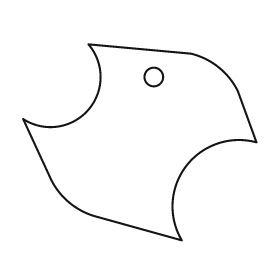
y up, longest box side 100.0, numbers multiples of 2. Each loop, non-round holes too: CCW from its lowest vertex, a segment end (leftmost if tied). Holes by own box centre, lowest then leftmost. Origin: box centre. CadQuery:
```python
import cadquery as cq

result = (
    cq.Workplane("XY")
    .moveTo(18.0, -42.0)
    .threePointArc((20.0, -10.0), (50.0, 0.0))
    .lineTo(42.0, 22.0)
    .threePointArc((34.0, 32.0), (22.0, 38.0))
    .lineTo(-22.0, 42.0)
    .threePointArc((-22.0, 14.0), (-50.0, 10.0))
    .lineTo(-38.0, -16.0)
    .threePointArc((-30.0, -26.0), (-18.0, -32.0))
    .close()
    .moveTo(6.0, 28.0)
    .circle(4.0)
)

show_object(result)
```